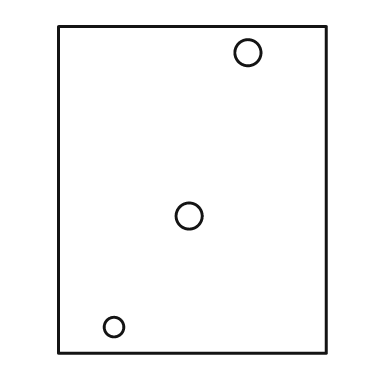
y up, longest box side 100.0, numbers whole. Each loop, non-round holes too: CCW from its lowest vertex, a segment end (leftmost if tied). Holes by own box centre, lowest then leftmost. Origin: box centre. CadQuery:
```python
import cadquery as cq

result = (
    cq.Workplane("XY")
    .moveTo(-41.0, -50.0)
    .lineTo(41.0, -50.0)
    .lineTo(41.0, 50.0)
    .lineTo(-41.0, 50.0)
    .close()
    .moveTo(-24.0, -42.0)
    .circle(3.0)
    .moveTo(-1.0, -8.0)
    .circle(4.0)
    .moveTo(17.0, 42.0)
    .circle(4.0)
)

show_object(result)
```